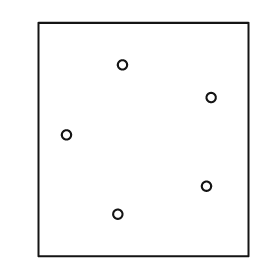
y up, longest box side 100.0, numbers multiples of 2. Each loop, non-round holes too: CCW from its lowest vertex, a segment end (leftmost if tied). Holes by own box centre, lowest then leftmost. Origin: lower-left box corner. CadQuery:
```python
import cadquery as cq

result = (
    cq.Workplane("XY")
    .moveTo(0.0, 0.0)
    .lineTo(90.0, 0.0)
    .lineTo(90.0, 100.0)
    .lineTo(0.0, 100.0)
    .close()
    .moveTo(34.0, 18.0)
    .circle(2.0)
    .moveTo(72.0, 30.0)
    .circle(2.0)
    .moveTo(12.0, 52.0)
    .circle(2.0)
    .moveTo(74.0, 68.0)
    .circle(2.0)
    .moveTo(36.0, 82.0)
    .circle(2.0)
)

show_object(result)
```